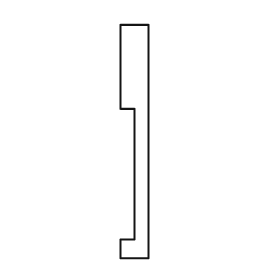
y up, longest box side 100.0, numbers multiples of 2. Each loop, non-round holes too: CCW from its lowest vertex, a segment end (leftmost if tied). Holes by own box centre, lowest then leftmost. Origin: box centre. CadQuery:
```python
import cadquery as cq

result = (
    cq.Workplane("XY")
    .moveTo(-6.0, -50.0)
    .lineTo(6.0, -50.0)
    .lineTo(6.0, 50.0)
    .lineTo(-6.0, 50.0)
    .lineTo(-6.0, 14.0)
    .lineTo(0.0, 14.0)
    .lineTo(0.0, -42.0)
    .lineTo(-6.0, -42.0)
    .close()
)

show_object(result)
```